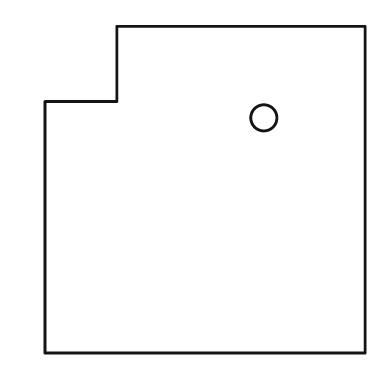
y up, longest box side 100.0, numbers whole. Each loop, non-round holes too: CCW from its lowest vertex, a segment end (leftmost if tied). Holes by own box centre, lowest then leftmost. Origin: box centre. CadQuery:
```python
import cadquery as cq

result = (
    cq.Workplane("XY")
    .moveTo(-49.0, -50.0)
    .lineTo(49.0, -50.0)
    .lineTo(49.0, 50.0)
    .lineTo(-27.0, 50.0)
    .lineTo(-27.0, 27.0)
    .lineTo(-49.0, 27.0)
    .close()
    .moveTo(18.0, 22.0)
    .circle(4.0)
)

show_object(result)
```